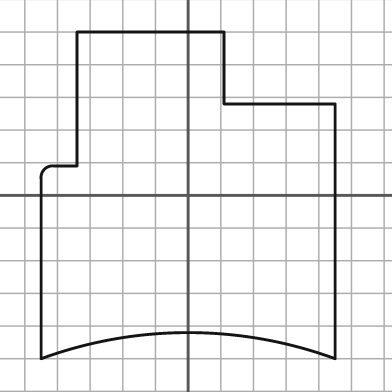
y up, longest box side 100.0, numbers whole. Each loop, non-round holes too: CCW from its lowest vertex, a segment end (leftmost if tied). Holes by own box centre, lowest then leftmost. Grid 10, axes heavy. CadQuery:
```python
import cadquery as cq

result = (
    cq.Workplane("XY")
    .moveTo(-45.0, -50.0)
    .threePointArc((0.0, -42.0), (45.0, -50.0))
    .lineTo(45.0, 28.0)
    .lineTo(11.0, 28.0)
    .lineTo(11.0, 50.0)
    .lineTo(-34.0, 50.0)
    .lineTo(-34.0, 9.0)
    .lineTo(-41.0, 9.0)
    .threePointArc((-44.0, 8.0), (-45.0, 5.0))
    .close()
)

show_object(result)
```